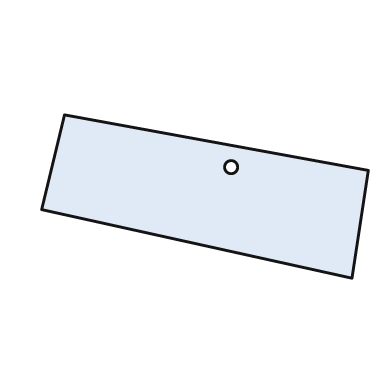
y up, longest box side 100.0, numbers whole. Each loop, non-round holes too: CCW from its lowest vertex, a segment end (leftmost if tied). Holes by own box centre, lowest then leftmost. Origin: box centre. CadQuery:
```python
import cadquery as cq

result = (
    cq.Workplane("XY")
    .moveTo(45.0, -25.0)
    .lineTo(50.0, 8.0)
    .lineTo(-43.0, 25.0)
    .lineTo(-50.0, -4.0)
    .close()
    .moveTo(8.0, 9.0)
    .circle(2.0)
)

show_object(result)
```